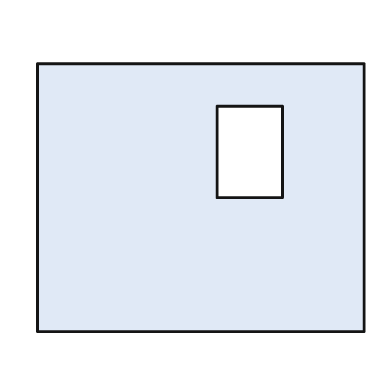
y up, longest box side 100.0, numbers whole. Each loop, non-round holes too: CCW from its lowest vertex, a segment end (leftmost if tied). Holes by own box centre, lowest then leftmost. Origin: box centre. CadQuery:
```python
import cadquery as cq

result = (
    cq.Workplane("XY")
    .moveTo(-50.0, -41.0)
    .lineTo(50.0, -41.0)
    .lineTo(50.0, 41.0)
    .lineTo(-50.0, 41.0)
    .close()
    .moveTo(5.0, 0.0)
    .lineTo(25.0, 0.0)
    .lineTo(25.0, 28.0)
    .lineTo(5.0, 28.0)
    .close()
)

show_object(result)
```